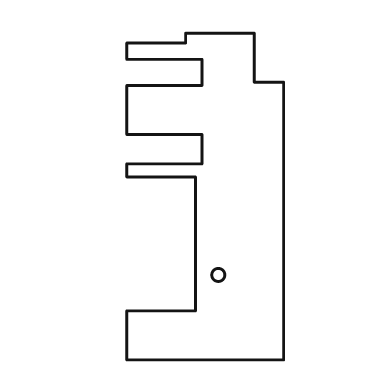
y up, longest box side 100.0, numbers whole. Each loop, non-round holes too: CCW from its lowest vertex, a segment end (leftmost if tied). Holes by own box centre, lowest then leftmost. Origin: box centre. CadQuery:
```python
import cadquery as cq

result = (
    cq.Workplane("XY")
    .moveTo(-24.0, -50.0)
    .lineTo(24.0, -50.0)
    .lineTo(24.0, 35.0)
    .lineTo(15.0, 35.0)
    .lineTo(15.0, 50.0)
    .lineTo(-6.0, 50.0)
    .lineTo(-6.0, 47.0)
    .lineTo(-24.0, 47.0)
    .lineTo(-24.0, 42.0)
    .lineTo(-1.0, 42.0)
    .lineTo(-1.0, 34.0)
    .lineTo(-24.0, 34.0)
    .lineTo(-24.0, 19.0)
    .lineTo(-1.0, 19.0)
    .lineTo(-1.0, 10.0)
    .lineTo(-24.0, 10.0)
    .lineTo(-24.0, 6.0)
    .lineTo(-3.0, 6.0)
    .lineTo(-3.0, -35.0)
    .lineTo(-24.0, -35.0)
    .close()
    .moveTo(4.0, -24.0)
    .circle(2.0)
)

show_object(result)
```